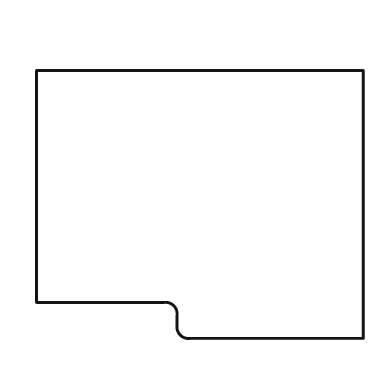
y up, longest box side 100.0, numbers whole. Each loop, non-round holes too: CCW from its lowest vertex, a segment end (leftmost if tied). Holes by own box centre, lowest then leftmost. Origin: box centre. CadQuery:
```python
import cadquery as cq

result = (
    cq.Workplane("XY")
    .moveTo(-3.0, -41.0)
    .lineTo(50.0, -41.0)
    .lineTo(50.0, 41.0)
    .lineTo(-50.0, 41.0)
    .lineTo(-50.0, -30.0)
    .lineTo(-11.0, -30.0)
    .threePointArc((-8.0, -31.0), (-7.0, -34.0))
    .lineTo(-7.0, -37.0)
    .threePointArc((-6.0, -40.0), (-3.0, -41.0))
    .close()
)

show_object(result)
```